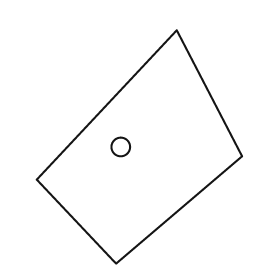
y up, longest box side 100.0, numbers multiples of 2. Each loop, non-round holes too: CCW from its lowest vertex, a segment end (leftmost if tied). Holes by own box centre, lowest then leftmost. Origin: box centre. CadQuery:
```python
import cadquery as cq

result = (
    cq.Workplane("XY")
    .moveTo(-10.0, -50.0)
    .lineTo(44.0, -4.0)
    .lineTo(16.0, 50.0)
    .lineTo(-44.0, -14.0)
    .close()
    .moveTo(-8.0, 0.0)
    .circle(4.0)
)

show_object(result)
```